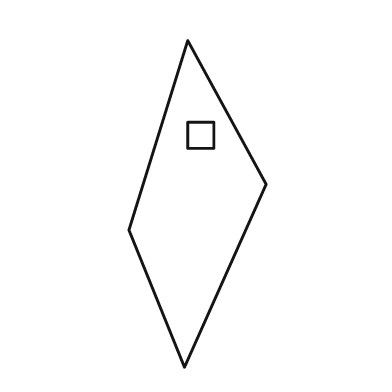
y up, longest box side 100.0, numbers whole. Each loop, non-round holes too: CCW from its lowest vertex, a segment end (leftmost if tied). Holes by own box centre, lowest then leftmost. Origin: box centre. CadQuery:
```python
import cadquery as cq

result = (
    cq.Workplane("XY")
    .moveTo(-4.0, -50.0)
    .lineTo(21.0, 6.0)
    .lineTo(-3.0, 50.0)
    .lineTo(-21.0, -8.0)
    .close()
    .moveTo(-3.0, 17.0)
    .lineTo(5.0, 17.0)
    .lineTo(5.0, 25.0)
    .lineTo(-3.0, 25.0)
    .close()
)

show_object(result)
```